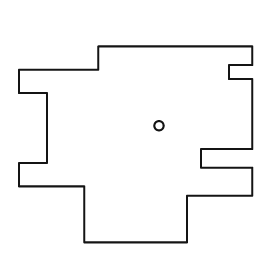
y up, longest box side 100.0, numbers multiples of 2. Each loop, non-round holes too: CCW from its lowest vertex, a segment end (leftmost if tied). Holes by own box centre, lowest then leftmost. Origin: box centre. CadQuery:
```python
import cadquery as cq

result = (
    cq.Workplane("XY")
    .moveTo(-22.0, -42.0)
    .lineTo(22.0, -42.0)
    .lineTo(22.0, -22.0)
    .lineTo(50.0, -22.0)
    .lineTo(50.0, -10.0)
    .lineTo(28.0, -10.0)
    .lineTo(28.0, -2.0)
    .lineTo(50.0, -2.0)
    .lineTo(50.0, 28.0)
    .lineTo(40.0, 28.0)
    .lineTo(40.0, 34.0)
    .lineTo(50.0, 34.0)
    .lineTo(50.0, 42.0)
    .lineTo(-16.0, 42.0)
    .lineTo(-16.0, 32.0)
    .lineTo(-50.0, 32.0)
    .lineTo(-50.0, 22.0)
    .lineTo(-38.0, 22.0)
    .lineTo(-38.0, -8.0)
    .lineTo(-50.0, -8.0)
    .lineTo(-50.0, -18.0)
    .lineTo(-22.0, -18.0)
    .close()
    .moveTo(10.0, 8.0)
    .circle(2.0)
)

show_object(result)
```